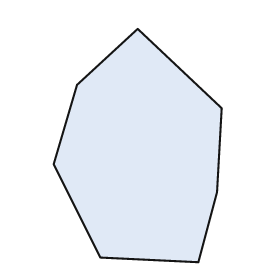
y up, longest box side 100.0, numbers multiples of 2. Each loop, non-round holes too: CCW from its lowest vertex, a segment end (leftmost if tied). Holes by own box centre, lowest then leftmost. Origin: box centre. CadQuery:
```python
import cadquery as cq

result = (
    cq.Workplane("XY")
    .moveTo(26.0, -50.0)
    .lineTo(34.0, -20.0)
    .lineTo(36.0, 16.0)
    .lineTo(0.0, 50.0)
    .lineTo(-26.0, 26.0)
    .lineTo(-36.0, -8.0)
    .lineTo(-16.0, -48.0)
    .close()
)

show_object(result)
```